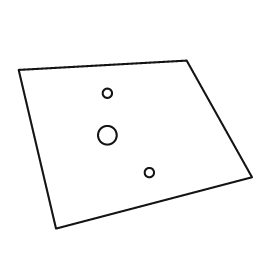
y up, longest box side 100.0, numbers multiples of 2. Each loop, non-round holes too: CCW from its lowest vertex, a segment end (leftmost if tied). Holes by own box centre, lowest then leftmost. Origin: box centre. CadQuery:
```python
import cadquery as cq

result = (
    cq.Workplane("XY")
    .moveTo(-34.0, -36.0)
    .lineTo(50.0, -14.0)
    .lineTo(22.0, 36.0)
    .lineTo(-50.0, 32.0)
    .close()
    .moveTo(6.0, -12.0)
    .circle(2.0)
    .moveTo(-12.0, 4.0)
    .circle(4.0)
    .moveTo(-12.0, 22.0)
    .circle(2.0)
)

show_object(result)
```